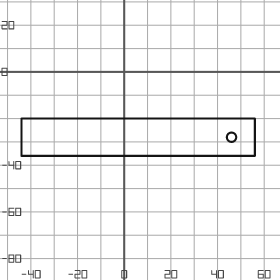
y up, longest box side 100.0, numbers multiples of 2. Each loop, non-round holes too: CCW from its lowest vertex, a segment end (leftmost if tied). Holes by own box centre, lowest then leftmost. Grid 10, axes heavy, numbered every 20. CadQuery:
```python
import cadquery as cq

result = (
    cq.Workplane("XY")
    .moveTo(-44.0, -36.0)
    .lineTo(56.0, -36.0)
    .lineTo(56.0, -20.0)
    .lineTo(-44.0, -20.0)
    .close()
    .moveTo(46.0, -28.0)
    .circle(2.0)
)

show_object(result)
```